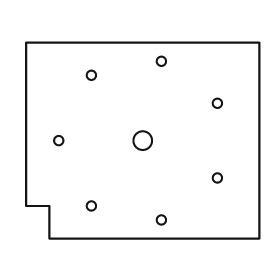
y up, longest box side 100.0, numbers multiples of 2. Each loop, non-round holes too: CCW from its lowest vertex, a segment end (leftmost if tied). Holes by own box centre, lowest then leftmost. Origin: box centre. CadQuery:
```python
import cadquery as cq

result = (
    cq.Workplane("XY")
    .moveTo(-40.0, -42.0)
    .lineTo(50.0, -42.0)
    .lineTo(50.0, 42.0)
    .lineTo(-50.0, 42.0)
    .lineTo(-50.0, -28.0)
    .lineTo(-40.0, -28.0)
    .close()
    .moveTo(8.0, -34.0)
    .circle(2.0)
    .moveTo(-22.0, -28.0)
    .circle(2.0)
    .moveTo(32.0, -16.0)
    .circle(2.0)
    .moveTo(-36.0, 0.0)
    .circle(2.0)
    .moveTo(0.0, 0.0)
    .circle(4.0)
    .moveTo(32.0, 16.0)
    .circle(2.0)
    .moveTo(-22.0, 28.0)
    .circle(2.0)
    .moveTo(8.0, 34.0)
    .circle(2.0)
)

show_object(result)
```